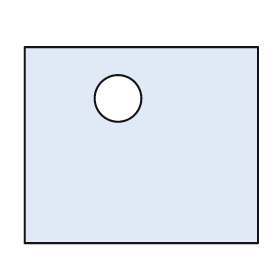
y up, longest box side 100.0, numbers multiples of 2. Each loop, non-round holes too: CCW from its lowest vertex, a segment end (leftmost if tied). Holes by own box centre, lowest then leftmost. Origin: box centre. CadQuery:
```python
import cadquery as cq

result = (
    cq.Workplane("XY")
    .moveTo(-50.0, -42.0)
    .lineTo(50.0, -42.0)
    .lineTo(50.0, 42.0)
    .lineTo(-50.0, 42.0)
    .close()
    .moveTo(-10.0, 20.0)
    .circle(10.0)
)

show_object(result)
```